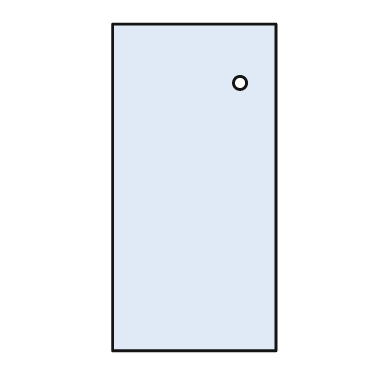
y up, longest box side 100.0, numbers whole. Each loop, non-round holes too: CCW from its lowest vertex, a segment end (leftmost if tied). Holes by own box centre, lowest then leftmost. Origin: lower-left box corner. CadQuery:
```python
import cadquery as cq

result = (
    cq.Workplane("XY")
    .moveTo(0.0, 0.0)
    .lineTo(50.0, 0.0)
    .lineTo(50.0, 100.0)
    .lineTo(0.0, 100.0)
    .close()
    .moveTo(39.0, 82.0)
    .circle(2.0)
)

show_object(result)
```